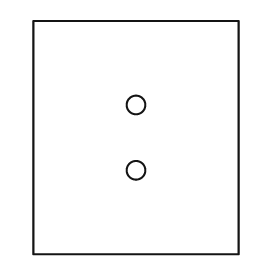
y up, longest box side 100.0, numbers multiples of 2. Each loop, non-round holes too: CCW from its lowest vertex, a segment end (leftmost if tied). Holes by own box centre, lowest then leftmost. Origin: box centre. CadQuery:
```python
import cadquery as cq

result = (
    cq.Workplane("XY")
    .moveTo(-44.0, -50.0)
    .lineTo(44.0, -50.0)
    .lineTo(44.0, 50.0)
    .lineTo(-44.0, 50.0)
    .close()
    .moveTo(0.0, -14.0)
    .circle(4.0)
    .moveTo(0.0, 14.0)
    .circle(4.0)
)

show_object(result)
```